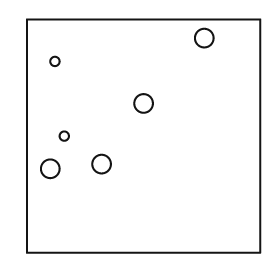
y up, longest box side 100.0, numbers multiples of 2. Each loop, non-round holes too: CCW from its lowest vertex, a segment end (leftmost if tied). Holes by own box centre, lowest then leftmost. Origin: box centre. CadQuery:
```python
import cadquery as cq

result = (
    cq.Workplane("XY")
    .moveTo(-50.0, -50.0)
    .lineTo(50.0, -50.0)
    .lineTo(50.0, 50.0)
    .lineTo(-50.0, 50.0)
    .close()
    .moveTo(-40.0, -14.0)
    .circle(4.0)
    .moveTo(-18.0, -12.0)
    .circle(4.0)
    .moveTo(-34.0, 0.0)
    .circle(2.0)
    .moveTo(0.0, 14.0)
    .circle(4.0)
    .moveTo(-38.0, 32.0)
    .circle(2.0)
    .moveTo(26.0, 42.0)
    .circle(4.0)
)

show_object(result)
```